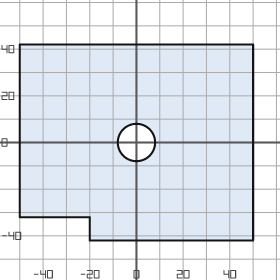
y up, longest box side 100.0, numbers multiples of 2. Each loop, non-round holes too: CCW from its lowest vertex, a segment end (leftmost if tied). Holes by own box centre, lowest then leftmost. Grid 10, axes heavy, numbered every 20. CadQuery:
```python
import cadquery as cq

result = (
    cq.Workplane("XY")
    .moveTo(-20.0, -42.0)
    .lineTo(50.0, -42.0)
    .lineTo(50.0, 42.0)
    .lineTo(-50.0, 42.0)
    .lineTo(-50.0, -32.0)
    .lineTo(-20.0, -32.0)
    .close()
    .moveTo(0.0, 0.0)
    .circle(8.0)
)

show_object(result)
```